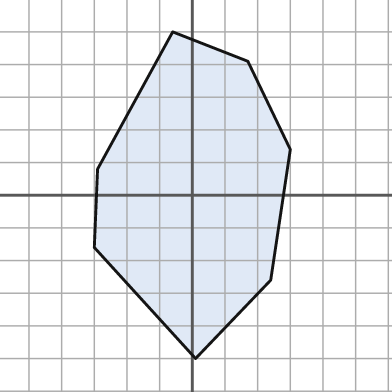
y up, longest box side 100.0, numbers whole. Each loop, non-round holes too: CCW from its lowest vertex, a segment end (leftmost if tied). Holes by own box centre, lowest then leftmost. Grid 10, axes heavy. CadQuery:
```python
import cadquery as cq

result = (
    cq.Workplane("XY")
    .moveTo(1.0, -50.0)
    .lineTo(24.0, -26.0)
    .lineTo(30.0, 14.0)
    .lineTo(17.0, 41.0)
    .lineTo(-6.0, 50.0)
    .lineTo(-29.0, 8.0)
    .lineTo(-30.0, -16.0)
    .close()
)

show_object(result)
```